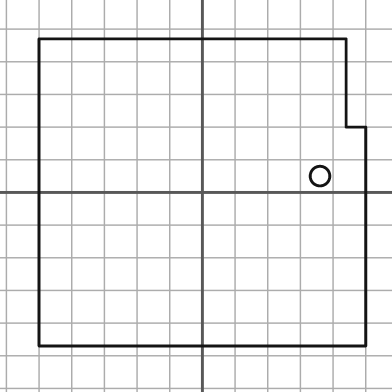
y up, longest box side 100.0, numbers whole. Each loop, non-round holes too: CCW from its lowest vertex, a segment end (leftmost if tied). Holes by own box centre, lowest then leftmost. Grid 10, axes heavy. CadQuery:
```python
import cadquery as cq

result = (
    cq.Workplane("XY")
    .moveTo(-50.0, -47.0)
    .lineTo(50.0, -47.0)
    .lineTo(50.0, 20.0)
    .lineTo(44.0, 20.0)
    .lineTo(44.0, 47.0)
    .lineTo(-50.0, 47.0)
    .close()
    .moveTo(36.0, 5.0)
    .circle(3.0)
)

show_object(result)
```